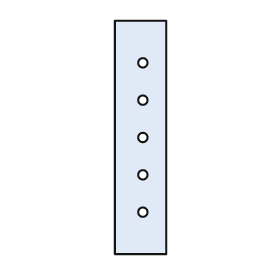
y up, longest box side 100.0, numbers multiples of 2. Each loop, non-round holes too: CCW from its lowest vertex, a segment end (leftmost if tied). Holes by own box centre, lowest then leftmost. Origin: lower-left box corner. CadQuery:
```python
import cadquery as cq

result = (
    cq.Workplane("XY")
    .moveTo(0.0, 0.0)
    .lineTo(22.0, 0.0)
    .lineTo(22.0, 100.0)
    .lineTo(0.0, 100.0)
    .close()
    .moveTo(12.0, 18.0)
    .circle(2.0)
    .moveTo(12.0, 34.0)
    .circle(2.0)
    .moveTo(12.0, 50.0)
    .circle(2.0)
    .moveTo(12.0, 66.0)
    .circle(2.0)
    .moveTo(12.0, 82.0)
    .circle(2.0)
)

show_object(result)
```